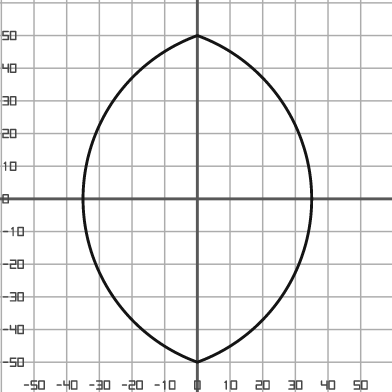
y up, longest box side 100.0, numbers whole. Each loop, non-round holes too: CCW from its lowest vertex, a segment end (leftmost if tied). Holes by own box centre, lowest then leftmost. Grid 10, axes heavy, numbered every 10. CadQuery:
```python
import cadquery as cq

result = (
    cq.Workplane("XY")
    .moveTo(0.0, -50.0)
    .threePointArc((35.0, 0.0), (0.0, 50.0))
    .threePointArc((-35.0, 0.0), (0.0, -50.0))
    .close()
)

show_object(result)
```